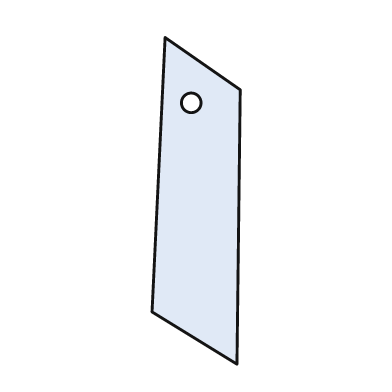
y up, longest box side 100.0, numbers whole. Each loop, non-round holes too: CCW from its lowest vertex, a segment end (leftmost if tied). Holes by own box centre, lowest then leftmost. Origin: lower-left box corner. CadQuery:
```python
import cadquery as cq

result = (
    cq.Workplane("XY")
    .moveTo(26.0, 0.0)
    .lineTo(27.0, 84.0)
    .lineTo(4.0, 100.0)
    .lineTo(0.0, 16.0)
    .close()
    .moveTo(12.0, 80.0)
    .circle(3.0)
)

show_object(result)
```